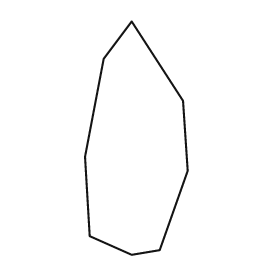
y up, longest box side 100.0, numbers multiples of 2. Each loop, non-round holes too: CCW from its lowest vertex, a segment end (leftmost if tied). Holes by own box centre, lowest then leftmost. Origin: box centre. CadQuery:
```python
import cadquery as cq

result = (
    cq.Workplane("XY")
    .moveTo(-2.0, -50.0)
    .lineTo(10.0, -48.0)
    .lineTo(22.0, -14.0)
    .lineTo(20.0, 16.0)
    .lineTo(-2.0, 50.0)
    .lineTo(-14.0, 34.0)
    .lineTo(-22.0, -8.0)
    .lineTo(-20.0, -42.0)
    .close()
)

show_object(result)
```